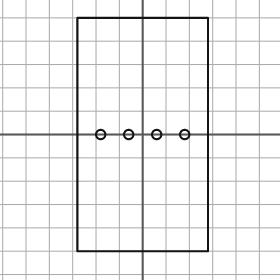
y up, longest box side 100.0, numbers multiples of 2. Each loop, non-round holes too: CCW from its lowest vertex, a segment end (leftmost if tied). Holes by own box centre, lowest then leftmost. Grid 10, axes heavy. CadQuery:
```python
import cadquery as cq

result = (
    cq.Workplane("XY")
    .moveTo(-28.0, -50.0)
    .lineTo(28.0, -50.0)
    .lineTo(28.0, 50.0)
    .lineTo(-28.0, 50.0)
    .close()
    .moveTo(-18.0, 0.0)
    .circle(2.0)
    .moveTo(-6.0, 0.0)
    .circle(2.0)
    .moveTo(6.0, 0.0)
    .circle(2.0)
    .moveTo(18.0, 0.0)
    .circle(2.0)
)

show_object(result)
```